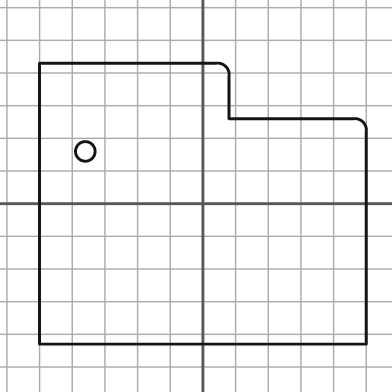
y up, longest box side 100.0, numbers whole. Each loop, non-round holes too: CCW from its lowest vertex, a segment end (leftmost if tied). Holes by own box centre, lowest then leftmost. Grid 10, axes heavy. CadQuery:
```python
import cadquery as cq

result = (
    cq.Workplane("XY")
    .moveTo(-50.0, -43.0)
    .lineTo(50.0, -43.0)
    .lineTo(50.0, 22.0)
    .threePointArc((49.0, 25.0), (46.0, 26.0))
    .lineTo(8.0, 26.0)
    .lineTo(8.0, 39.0)
    .threePointArc((7.0, 42.0), (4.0, 43.0))
    .lineTo(-50.0, 43.0)
    .close()
    .moveTo(-36.0, 16.0)
    .circle(3.0)
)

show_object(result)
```